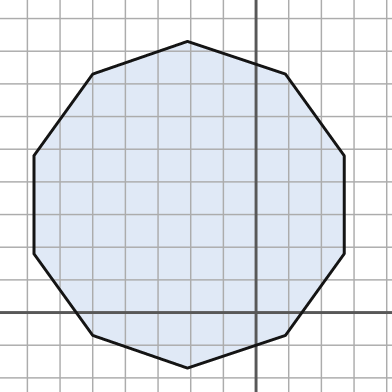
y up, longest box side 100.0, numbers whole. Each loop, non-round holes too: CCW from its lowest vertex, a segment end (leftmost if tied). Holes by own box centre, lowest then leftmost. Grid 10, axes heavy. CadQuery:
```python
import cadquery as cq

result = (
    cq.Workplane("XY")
    .moveTo(-21.0, -17.0)
    .lineTo(9.0, -7.0)
    .lineTo(27.0, 18.0)
    .lineTo(27.0, 48.0)
    .lineTo(9.0, 73.0)
    .lineTo(-21.0, 83.0)
    .lineTo(-50.0, 73.0)
    .lineTo(-68.0, 48.0)
    .lineTo(-68.0, 18.0)
    .lineTo(-50.0, -7.0)
    .close()
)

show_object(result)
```